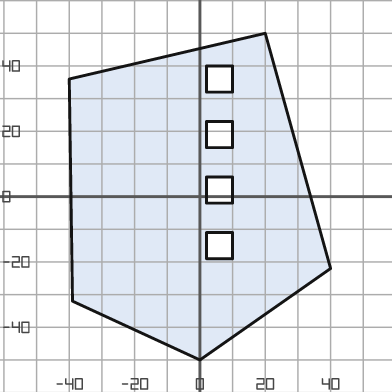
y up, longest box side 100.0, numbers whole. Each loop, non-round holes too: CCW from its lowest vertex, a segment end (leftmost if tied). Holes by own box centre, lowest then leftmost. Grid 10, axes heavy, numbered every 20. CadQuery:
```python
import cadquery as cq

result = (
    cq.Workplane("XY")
    .moveTo(0.0, -50.0)
    .lineTo(40.0, -22.0)
    .lineTo(20.0, 50.0)
    .lineTo(-40.0, 36.0)
    .lineTo(-39.0, -32.0)
    .close()
    .moveTo(2.0, -19.0)
    .lineTo(10.0, -19.0)
    .lineTo(10.0, -11.0)
    .lineTo(2.0, -11.0)
    .close()
    .moveTo(2.0, -2.0)
    .lineTo(10.0, -2.0)
    .lineTo(10.0, 6.0)
    .lineTo(2.0, 6.0)
    .close()
    .moveTo(2.0, 15.0)
    .lineTo(10.0, 15.0)
    .lineTo(10.0, 23.0)
    .lineTo(2.0, 23.0)
    .close()
    .moveTo(2.0, 32.0)
    .lineTo(10.0, 32.0)
    .lineTo(10.0, 40.0)
    .lineTo(2.0, 40.0)
    .close()
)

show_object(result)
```